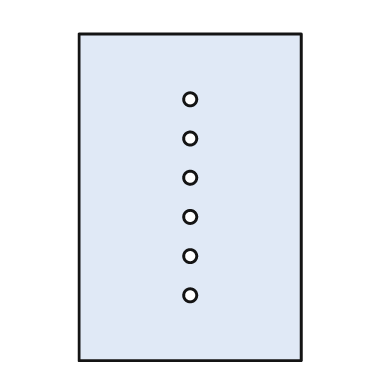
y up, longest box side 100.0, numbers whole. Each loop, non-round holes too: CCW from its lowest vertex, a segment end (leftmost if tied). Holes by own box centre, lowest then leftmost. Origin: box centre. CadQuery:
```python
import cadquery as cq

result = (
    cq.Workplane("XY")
    .moveTo(-34.0, -50.0)
    .lineTo(34.0, -50.0)
    .lineTo(34.0, 50.0)
    .lineTo(-34.0, 50.0)
    .close()
    .moveTo(0.0, -30.0)
    .circle(2.0)
    .moveTo(0.0, -18.0)
    .circle(2.0)
    .moveTo(0.0, -6.0)
    .circle(2.0)
    .moveTo(0.0, 6.0)
    .circle(2.0)
    .moveTo(0.0, 18.0)
    .circle(2.0)
    .moveTo(0.0, 30.0)
    .circle(2.0)
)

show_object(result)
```